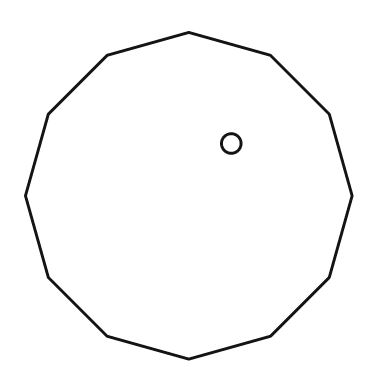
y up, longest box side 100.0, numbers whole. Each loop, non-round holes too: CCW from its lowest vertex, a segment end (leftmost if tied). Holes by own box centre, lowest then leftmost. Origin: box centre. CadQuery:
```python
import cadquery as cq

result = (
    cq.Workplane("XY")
    .moveTo(0.0, -50.0)
    .lineTo(25.0, -43.0)
    .lineTo(43.0, -25.0)
    .lineTo(50.0, 0.0)
    .lineTo(43.0, 25.0)
    .lineTo(25.0, 43.0)
    .lineTo(0.0, 50.0)
    .lineTo(-25.0, 43.0)
    .lineTo(-43.0, 25.0)
    .lineTo(-50.0, 0.0)
    .lineTo(-43.0, -25.0)
    .lineTo(-25.0, -43.0)
    .close()
    .moveTo(13.0, 16.0)
    .circle(3.0)
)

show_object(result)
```